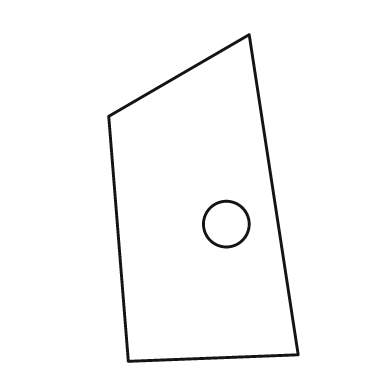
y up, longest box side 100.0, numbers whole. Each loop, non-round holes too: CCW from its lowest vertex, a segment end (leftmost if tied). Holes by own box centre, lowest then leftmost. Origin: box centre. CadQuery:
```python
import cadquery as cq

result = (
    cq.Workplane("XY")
    .moveTo(-23.0, -50.0)
    .lineTo(29.0, -48.0)
    .lineTo(14.0, 50.0)
    .lineTo(-29.0, 25.0)
    .close()
    .moveTo(7.0, -8.0)
    .circle(7.0)
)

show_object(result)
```